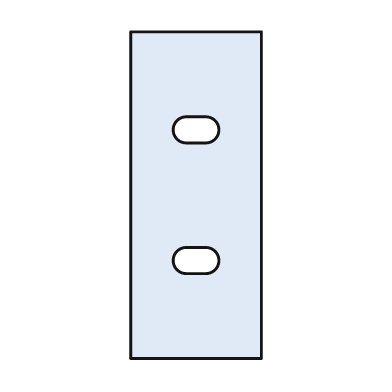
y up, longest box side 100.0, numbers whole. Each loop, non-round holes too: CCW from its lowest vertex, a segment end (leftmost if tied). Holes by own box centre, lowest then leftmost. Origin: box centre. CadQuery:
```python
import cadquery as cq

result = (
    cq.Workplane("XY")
    .moveTo(-20.0, -50.0)
    .lineTo(20.0, -50.0)
    .lineTo(20.0, 50.0)
    .lineTo(-20.0, 50.0)
    .close()
    .moveTo(-3.0, -24.0)
    .lineTo(3.0, -24.0)
    .threePointArc((7.0, -20.0), (3.0, -16.0))
    .lineTo(-3.0, -16.0)
    .threePointArc((-7.0, -20.0), (-3.0, -24.0))
    .close()
    .moveTo(-3.0, 16.0)
    .lineTo(3.0, 16.0)
    .threePointArc((7.0, 20.0), (3.0, 24.0))
    .lineTo(-3.0, 24.0)
    .threePointArc((-7.0, 20.0), (-3.0, 16.0))
    .close()
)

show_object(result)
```